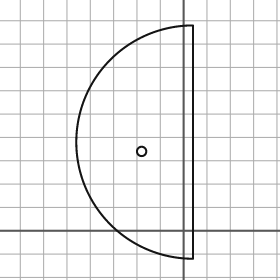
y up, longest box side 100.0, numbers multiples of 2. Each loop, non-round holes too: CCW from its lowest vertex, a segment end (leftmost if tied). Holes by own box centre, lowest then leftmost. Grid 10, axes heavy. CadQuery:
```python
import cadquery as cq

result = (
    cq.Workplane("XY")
    .moveTo(4.0, -12.0)
    .lineTo(4.0, 88.0)
    .threePointArc((-46.0, 38.0), (4.0, -12.0))
    .close()
    .moveTo(-18.0, 34.0)
    .circle(2.0)
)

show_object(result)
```